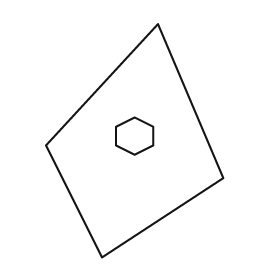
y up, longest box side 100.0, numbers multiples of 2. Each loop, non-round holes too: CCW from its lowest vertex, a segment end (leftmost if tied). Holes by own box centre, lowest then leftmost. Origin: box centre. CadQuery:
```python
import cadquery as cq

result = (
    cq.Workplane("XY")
    .moveTo(-14.0, -50.0)
    .lineTo(38.0, -16.0)
    .lineTo(10.0, 50.0)
    .lineTo(-38.0, -2.0)
    .close()
    .moveTo(0.0, -6.0)
    .lineTo(8.0, -2.0)
    .lineTo(8.0, 6.0)
    .lineTo(0.0, 10.0)
    .lineTo(-8.0, 6.0)
    .lineTo(-8.0, -2.0)
    .close()
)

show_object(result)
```